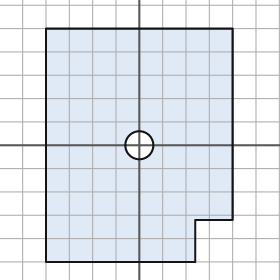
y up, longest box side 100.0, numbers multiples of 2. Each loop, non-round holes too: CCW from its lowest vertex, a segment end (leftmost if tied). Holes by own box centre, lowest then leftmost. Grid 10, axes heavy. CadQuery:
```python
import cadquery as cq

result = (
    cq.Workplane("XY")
    .moveTo(-40.0, -50.0)
    .lineTo(24.0, -50.0)
    .lineTo(24.0, -32.0)
    .lineTo(40.0, -32.0)
    .lineTo(40.0, 50.0)
    .lineTo(-40.0, 50.0)
    .close()
    .moveTo(0.0, 0.0)
    .circle(6.0)
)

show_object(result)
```